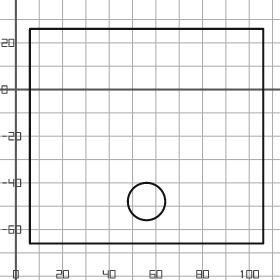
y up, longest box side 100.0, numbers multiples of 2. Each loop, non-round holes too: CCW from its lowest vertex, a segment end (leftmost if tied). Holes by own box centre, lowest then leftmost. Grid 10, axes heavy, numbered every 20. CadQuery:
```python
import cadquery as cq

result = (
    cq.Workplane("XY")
    .moveTo(6.0, -66.0)
    .lineTo(106.0, -66.0)
    .lineTo(106.0, 26.0)
    .lineTo(6.0, 26.0)
    .close()
    .moveTo(56.0, -48.0)
    .circle(8.0)
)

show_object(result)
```